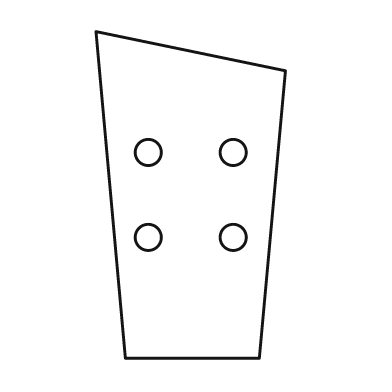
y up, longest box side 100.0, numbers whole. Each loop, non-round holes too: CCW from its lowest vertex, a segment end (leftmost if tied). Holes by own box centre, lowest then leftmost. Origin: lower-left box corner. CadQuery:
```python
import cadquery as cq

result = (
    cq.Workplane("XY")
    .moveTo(9.0, 0.0)
    .lineTo(50.0, 0.0)
    .lineTo(58.0, 88.0)
    .lineTo(0.0, 100.0)
    .close()
    .moveTo(16.0, 37.0)
    .circle(4.0)
    .moveTo(42.0, 37.0)
    .circle(4.0)
    .moveTo(16.0, 63.0)
    .circle(4.0)
    .moveTo(42.0, 63.0)
    .circle(4.0)
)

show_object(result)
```